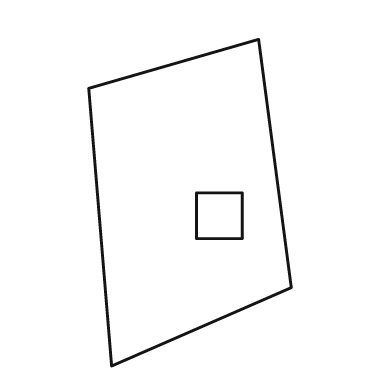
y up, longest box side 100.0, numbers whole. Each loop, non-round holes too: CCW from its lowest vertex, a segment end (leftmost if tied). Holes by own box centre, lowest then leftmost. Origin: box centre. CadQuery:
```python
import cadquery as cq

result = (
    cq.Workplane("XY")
    .moveTo(-24.0, -50.0)
    .lineTo(31.0, -26.0)
    .lineTo(21.0, 50.0)
    .lineTo(-31.0, 35.0)
    .close()
    .moveTo(2.0, -11.0)
    .lineTo(16.0, -11.0)
    .lineTo(16.0, 3.0)
    .lineTo(2.0, 3.0)
    .close()
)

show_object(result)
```